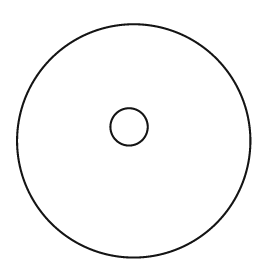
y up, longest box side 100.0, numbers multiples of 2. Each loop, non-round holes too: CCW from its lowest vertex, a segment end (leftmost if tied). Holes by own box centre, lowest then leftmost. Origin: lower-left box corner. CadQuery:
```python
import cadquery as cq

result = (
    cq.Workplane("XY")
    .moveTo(50.0, 50.0)
    .circle(50.0)
    .moveTo(48.0, 56.0)
    .circle(8.0)
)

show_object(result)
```